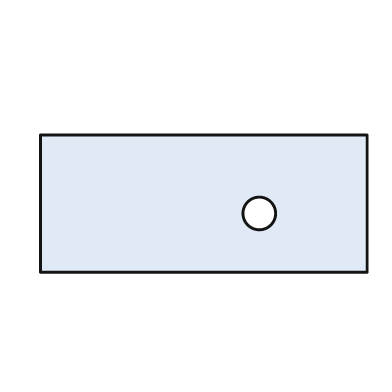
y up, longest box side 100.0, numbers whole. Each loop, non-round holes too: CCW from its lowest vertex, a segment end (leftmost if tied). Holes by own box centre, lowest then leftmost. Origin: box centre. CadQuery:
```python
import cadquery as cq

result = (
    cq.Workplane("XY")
    .moveTo(-50.0, -21.0)
    .lineTo(50.0, -21.0)
    .lineTo(50.0, 21.0)
    .lineTo(-50.0, 21.0)
    .close()
    .moveTo(17.0, -3.0)
    .circle(5.0)
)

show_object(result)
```